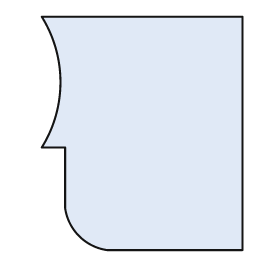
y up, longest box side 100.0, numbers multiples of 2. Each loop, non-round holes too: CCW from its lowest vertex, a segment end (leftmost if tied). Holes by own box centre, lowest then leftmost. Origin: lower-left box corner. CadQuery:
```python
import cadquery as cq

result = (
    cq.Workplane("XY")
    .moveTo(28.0, 0.0)
    .lineTo(86.0, 0.0)
    .lineTo(86.0, 100.0)
    .lineTo(0.0, 100.0)
    .threePointArc((8.0, 72.0), (0.0, 44.0))
    .lineTo(10.0, 44.0)
    .lineTo(10.0, 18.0)
    .threePointArc((16.0, 6.0), (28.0, 0.0))
    .close()
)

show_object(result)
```